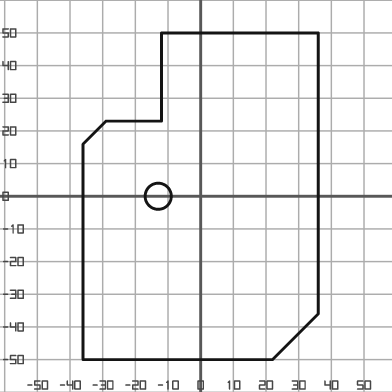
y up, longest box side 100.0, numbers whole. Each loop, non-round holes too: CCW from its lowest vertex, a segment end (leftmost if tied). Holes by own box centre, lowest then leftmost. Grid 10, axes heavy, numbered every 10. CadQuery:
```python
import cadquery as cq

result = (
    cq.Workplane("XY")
    .moveTo(-36.0, -50.0)
    .lineTo(22.0, -50.0)
    .lineTo(36.0, -36.0)
    .lineTo(36.0, 50.0)
    .lineTo(-12.0, 50.0)
    .lineTo(-12.0, 23.0)
    .lineTo(-29.0, 23.0)
    .lineTo(-36.0, 16.0)
    .close()
    .moveTo(-13.0, 0.0)
    .circle(4.0)
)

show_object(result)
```